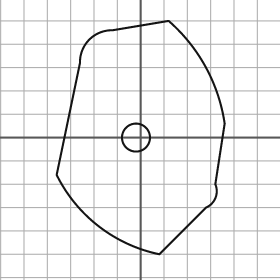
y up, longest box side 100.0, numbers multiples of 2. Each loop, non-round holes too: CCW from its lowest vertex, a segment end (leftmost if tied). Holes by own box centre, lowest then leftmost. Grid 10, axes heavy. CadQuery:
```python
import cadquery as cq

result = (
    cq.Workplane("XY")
    .moveTo(8.0, -50.0)
    .lineTo(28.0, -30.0)
    .threePointArc((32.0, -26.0), (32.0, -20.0))
    .lineTo(36.0, 6.0)
    .threePointArc((28.0, 30.0), (12.0, 50.0))
    .lineTo(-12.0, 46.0)
    .threePointArc((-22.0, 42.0), (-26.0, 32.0))
    .lineTo(-36.0, -16.0)
    .threePointArc((-18.0, -38.0), (8.0, -50.0))
    .close()
    .moveTo(-2.0, 0.0)
    .circle(6.0)
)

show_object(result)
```